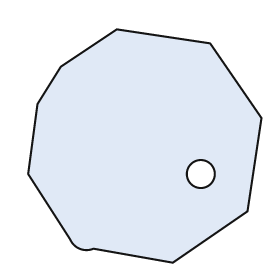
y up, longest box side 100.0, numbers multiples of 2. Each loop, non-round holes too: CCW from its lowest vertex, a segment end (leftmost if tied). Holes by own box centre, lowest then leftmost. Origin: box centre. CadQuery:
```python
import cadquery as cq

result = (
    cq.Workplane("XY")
    .moveTo(12.0, -50.0)
    .lineTo(44.0, -28.0)
    .lineTo(50.0, 12.0)
    .lineTo(28.0, 44.0)
    .lineTo(-12.0, 50.0)
    .lineTo(-36.0, 34.0)
    .lineTo(-46.0, 18.0)
    .lineTo(-50.0, -12.0)
    .lineTo(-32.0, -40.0)
    .threePointArc((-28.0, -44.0), (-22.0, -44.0))
    .close()
    .moveTo(24.0, -12.0)
    .circle(6.0)
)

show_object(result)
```